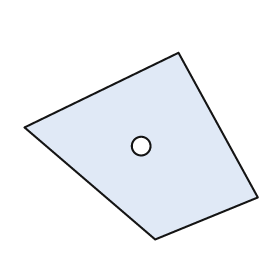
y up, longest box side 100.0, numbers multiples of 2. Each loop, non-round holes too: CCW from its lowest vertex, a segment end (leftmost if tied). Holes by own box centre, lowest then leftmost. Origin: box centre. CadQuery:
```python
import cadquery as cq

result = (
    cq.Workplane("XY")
    .moveTo(6.0, -40.0)
    .lineTo(50.0, -22.0)
    .lineTo(16.0, 40.0)
    .lineTo(-50.0, 8.0)
    .close()
    .moveTo(0.0, 0.0)
    .circle(4.0)
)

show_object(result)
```